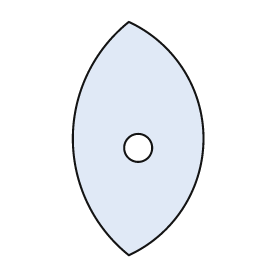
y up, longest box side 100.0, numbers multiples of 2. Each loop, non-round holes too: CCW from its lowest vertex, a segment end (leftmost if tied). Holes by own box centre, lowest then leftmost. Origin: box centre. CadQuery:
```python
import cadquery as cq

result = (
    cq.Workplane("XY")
    .moveTo(-4.0, -50.0)
    .threePointArc((28.0, 0.0), (-4.0, 50.0))
    .threePointArc((-28.0, 0.0), (-4.0, -50.0))
    .close()
    .moveTo(0.0, -4.0)
    .circle(6.0)
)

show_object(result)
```